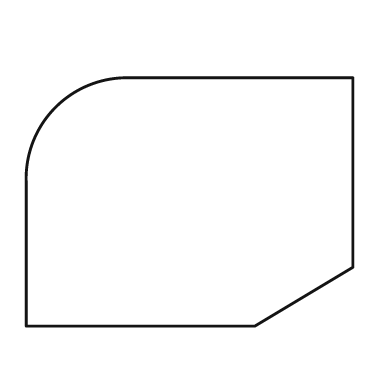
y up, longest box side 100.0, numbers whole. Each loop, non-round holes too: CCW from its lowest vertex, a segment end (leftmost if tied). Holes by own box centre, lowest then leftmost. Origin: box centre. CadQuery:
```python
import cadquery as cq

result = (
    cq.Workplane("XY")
    .moveTo(-50.0, -38.0)
    .lineTo(20.0, -38.0)
    .lineTo(50.0, -20.0)
    .lineTo(50.0, 38.0)
    .lineTo(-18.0, 38.0)
    .threePointArc((-41.0, 29.0), (-50.0, 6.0))
    .close()
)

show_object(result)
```